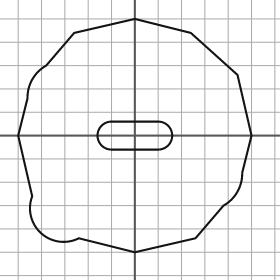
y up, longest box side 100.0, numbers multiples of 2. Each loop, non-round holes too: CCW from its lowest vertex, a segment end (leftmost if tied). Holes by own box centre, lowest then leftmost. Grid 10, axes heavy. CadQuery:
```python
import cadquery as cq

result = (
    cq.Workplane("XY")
    .moveTo(0.0, -50.0)
    .lineTo(26.0, -44.0)
    .lineTo(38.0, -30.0)
    .threePointArc((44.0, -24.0), (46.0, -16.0))
    .lineTo(50.0, 0.0)
    .lineTo(44.0, 26.0)
    .lineTo(24.0, 44.0)
    .lineTo(0.0, 50.0)
    .lineTo(-26.0, 44.0)
    .lineTo(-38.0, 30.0)
    .threePointArc((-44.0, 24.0), (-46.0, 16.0))
    .lineTo(-50.0, 0.0)
    .lineTo(-44.0, -26.0)
    .threePointArc((-40.0, -42.0), (-24.0, -44.0))
    .close()
    .moveTo(-10.0, -6.0)
    .lineTo(10.0, -6.0)
    .threePointArc((16.0, 0.0), (10.0, 6.0))
    .lineTo(-10.0, 6.0)
    .threePointArc((-16.0, 0.0), (-10.0, -6.0))
    .close()
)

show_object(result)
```